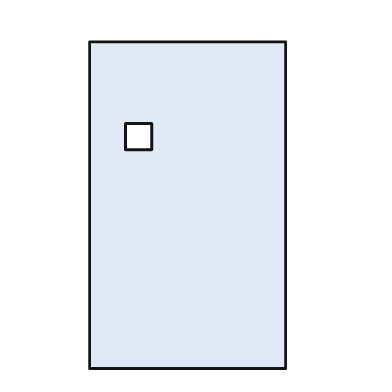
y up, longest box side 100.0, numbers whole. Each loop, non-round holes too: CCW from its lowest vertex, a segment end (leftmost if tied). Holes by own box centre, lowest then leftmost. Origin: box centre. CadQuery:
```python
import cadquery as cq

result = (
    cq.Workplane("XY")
    .moveTo(-30.0, -50.0)
    .lineTo(30.0, -50.0)
    .lineTo(30.0, 50.0)
    .lineTo(-30.0, 50.0)
    .close()
    .moveTo(-19.0, 17.0)
    .lineTo(-11.0, 17.0)
    .lineTo(-11.0, 25.0)
    .lineTo(-19.0, 25.0)
    .close()
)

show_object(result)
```